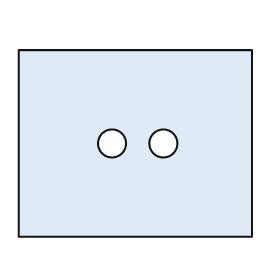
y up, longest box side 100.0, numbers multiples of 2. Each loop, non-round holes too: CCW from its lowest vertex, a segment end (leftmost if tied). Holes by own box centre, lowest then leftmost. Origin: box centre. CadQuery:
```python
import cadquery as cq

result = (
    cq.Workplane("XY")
    .moveTo(-50.0, -40.0)
    .lineTo(50.0, -40.0)
    .lineTo(50.0, 40.0)
    .lineTo(-50.0, 40.0)
    .close()
    .moveTo(-10.0, 0.0)
    .circle(6.0)
    .moveTo(12.0, 0.0)
    .circle(6.0)
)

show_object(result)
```